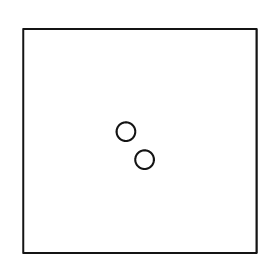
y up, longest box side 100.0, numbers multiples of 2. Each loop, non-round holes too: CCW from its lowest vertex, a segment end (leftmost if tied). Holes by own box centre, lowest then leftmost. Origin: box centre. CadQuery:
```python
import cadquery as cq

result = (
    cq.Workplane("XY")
    .moveTo(-50.0, -48.0)
    .lineTo(50.0, -48.0)
    .lineTo(50.0, 48.0)
    .lineTo(-50.0, 48.0)
    .close()
    .moveTo(2.0, -8.0)
    .circle(4.0)
    .moveTo(-6.0, 4.0)
    .circle(4.0)
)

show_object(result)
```